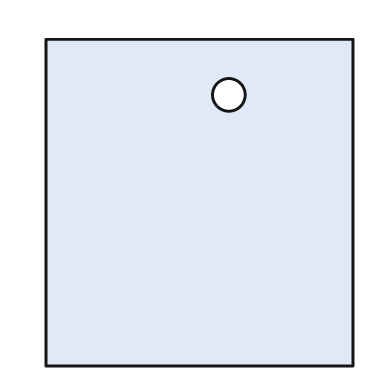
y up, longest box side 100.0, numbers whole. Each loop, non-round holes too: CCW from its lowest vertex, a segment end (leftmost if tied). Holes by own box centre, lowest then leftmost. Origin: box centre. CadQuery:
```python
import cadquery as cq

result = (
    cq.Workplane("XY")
    .moveTo(-47.0, -50.0)
    .lineTo(47.0, -50.0)
    .lineTo(47.0, 50.0)
    .lineTo(-47.0, 50.0)
    .close()
    .moveTo(9.0, 33.0)
    .circle(5.0)
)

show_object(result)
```